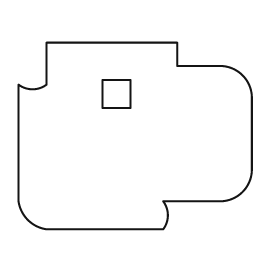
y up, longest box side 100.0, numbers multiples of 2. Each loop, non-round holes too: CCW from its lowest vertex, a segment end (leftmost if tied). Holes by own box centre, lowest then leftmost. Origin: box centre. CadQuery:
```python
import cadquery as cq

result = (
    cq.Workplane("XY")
    .moveTo(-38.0, -40.0)
    .lineTo(12.0, -40.0)
    .threePointArc((14.0, -34.0), (12.0, -28.0))
    .lineTo(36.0, -28.0)
    .threePointArc((46.0, -24.0), (50.0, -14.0))
    .lineTo(50.0, 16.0)
    .threePointArc((46.0, 26.0), (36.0, 30.0))
    .lineTo(18.0, 30.0)
    .lineTo(18.0, 40.0)
    .lineTo(-38.0, 40.0)
    .lineTo(-38.0, 22.0)
    .threePointArc((-44.0, 20.0), (-50.0, 22.0))
    .lineTo(-50.0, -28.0)
    .threePointArc((-46.0, -36.0), (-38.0, -40.0))
    .close()
    .moveTo(-14.0, 12.0)
    .lineTo(-2.0, 12.0)
    .lineTo(-2.0, 24.0)
    .lineTo(-14.0, 24.0)
    .close()
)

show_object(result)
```